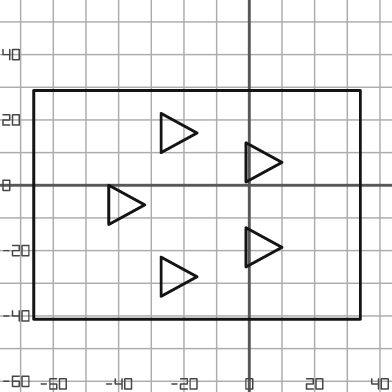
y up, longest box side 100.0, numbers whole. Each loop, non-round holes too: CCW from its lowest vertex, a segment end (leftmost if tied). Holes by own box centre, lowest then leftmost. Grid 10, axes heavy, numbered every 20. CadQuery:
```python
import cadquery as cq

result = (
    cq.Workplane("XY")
    .moveTo(-66.0, -41.0)
    .lineTo(34.0, -41.0)
    .lineTo(34.0, 29.0)
    .lineTo(-66.0, 29.0)
    .close()
    .moveTo(-27.0, -34.0)
    .lineTo(-16.0, -28.0)
    .lineTo(-27.0, -22.0)
    .close()
    .moveTo(-1.0, -25.0)
    .lineTo(10.0, -19.0)
    .lineTo(-1.0, -13.0)
    .close()
    .moveTo(-43.0, -12.0)
    .lineTo(-32.0, -6.0)
    .lineTo(-43.0, 0.0)
    .close()
    .moveTo(-1.0, 1.0)
    .lineTo(10.0, 7.0)
    .lineTo(-1.0, 13.0)
    .close()
    .moveTo(-27.0, 10.0)
    .lineTo(-16.0, 16.0)
    .lineTo(-27.0, 22.0)
    .close()
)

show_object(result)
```